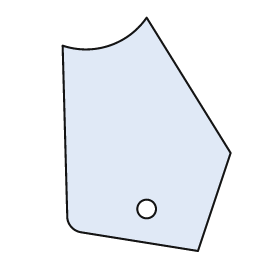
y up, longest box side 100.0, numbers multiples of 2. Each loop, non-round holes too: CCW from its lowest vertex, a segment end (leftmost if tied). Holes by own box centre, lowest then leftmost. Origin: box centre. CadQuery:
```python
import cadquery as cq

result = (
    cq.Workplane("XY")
    .moveTo(22.0, -50.0)
    .lineTo(36.0, -8.0)
    .lineTo(0.0, 50.0)
    .threePointArc((-16.0, 38.0), (-36.0, 38.0))
    .lineTo(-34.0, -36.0)
    .threePointArc((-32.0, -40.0), (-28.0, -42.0))
    .close()
    .moveTo(0.0, -32.0)
    .circle(4.0)
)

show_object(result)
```